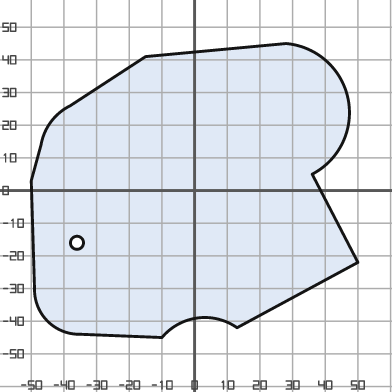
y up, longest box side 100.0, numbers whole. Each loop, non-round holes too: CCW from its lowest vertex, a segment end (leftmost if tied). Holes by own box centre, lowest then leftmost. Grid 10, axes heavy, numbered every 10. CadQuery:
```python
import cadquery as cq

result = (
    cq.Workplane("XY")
    .moveTo(-10.0, -45.0)
    .threePointArc((1.0, -39.0), (13.0, -42.0))
    .lineTo(50.0, -22.0)
    .lineTo(36.0, 5.0)
    .threePointArc((47.0, 28.0), (28.0, 45.0))
    .lineTo(-15.0, 41.0)
    .lineTo(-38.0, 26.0)
    .threePointArc((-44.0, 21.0), (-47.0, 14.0))
    .lineTo(-50.0, 3.0)
    .lineTo(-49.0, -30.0)
    .threePointArc((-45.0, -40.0), (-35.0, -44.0))
    .close()
    .moveTo(-36.0, -16.0)
    .circle(2.0)
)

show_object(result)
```